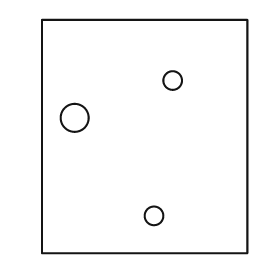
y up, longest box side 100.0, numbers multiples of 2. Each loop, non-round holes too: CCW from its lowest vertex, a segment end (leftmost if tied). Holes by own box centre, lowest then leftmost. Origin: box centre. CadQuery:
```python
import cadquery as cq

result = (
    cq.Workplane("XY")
    .moveTo(-44.0, -50.0)
    .lineTo(44.0, -50.0)
    .lineTo(44.0, 50.0)
    .lineTo(-44.0, 50.0)
    .close()
    .moveTo(4.0, -34.0)
    .circle(4.0)
    .moveTo(-30.0, 8.0)
    .circle(6.0)
    .moveTo(12.0, 24.0)
    .circle(4.0)
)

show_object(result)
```